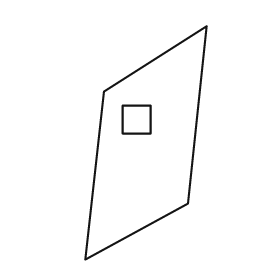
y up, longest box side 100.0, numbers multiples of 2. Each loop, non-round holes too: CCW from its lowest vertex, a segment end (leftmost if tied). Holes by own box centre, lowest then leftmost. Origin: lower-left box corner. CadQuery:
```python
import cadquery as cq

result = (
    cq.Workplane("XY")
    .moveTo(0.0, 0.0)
    .lineTo(44.0, 24.0)
    .lineTo(52.0, 100.0)
    .lineTo(8.0, 72.0)
    .close()
    .moveTo(16.0, 54.0)
    .lineTo(28.0, 54.0)
    .lineTo(28.0, 66.0)
    .lineTo(16.0, 66.0)
    .close()
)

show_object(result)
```